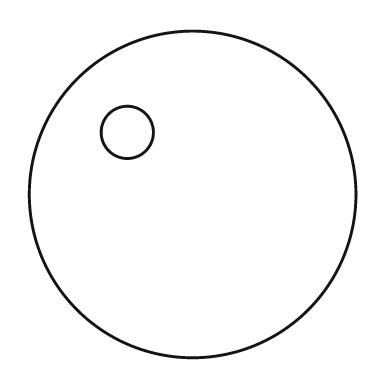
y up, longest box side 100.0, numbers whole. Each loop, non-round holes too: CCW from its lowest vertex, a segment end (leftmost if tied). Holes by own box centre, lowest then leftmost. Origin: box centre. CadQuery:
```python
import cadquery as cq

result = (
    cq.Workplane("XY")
    .moveTo(0.0, 0.0)
    .circle(50.0)
    .moveTo(-20.0, 19.0)
    .circle(8.0)
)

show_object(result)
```